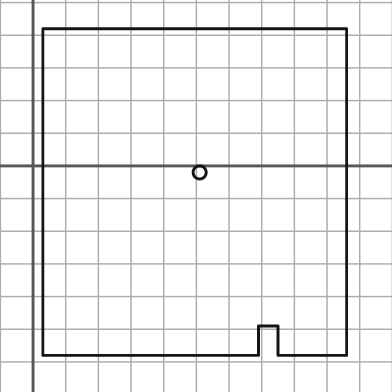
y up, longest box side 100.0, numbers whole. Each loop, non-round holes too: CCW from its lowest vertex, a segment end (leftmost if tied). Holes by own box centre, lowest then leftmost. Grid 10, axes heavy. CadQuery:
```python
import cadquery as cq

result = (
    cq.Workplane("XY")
    .moveTo(3.0, -58.0)
    .lineTo(69.0, -58.0)
    .lineTo(69.0, -49.0)
    .lineTo(75.0, -49.0)
    .lineTo(75.0, -58.0)
    .lineTo(96.0, -58.0)
    .lineTo(96.0, 42.0)
    .lineTo(3.0, 42.0)
    .close()
    .moveTo(51.0, -2.0)
    .circle(2.0)
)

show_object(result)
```